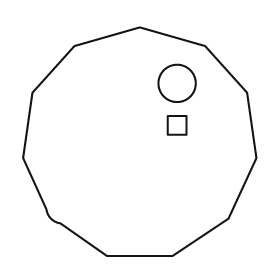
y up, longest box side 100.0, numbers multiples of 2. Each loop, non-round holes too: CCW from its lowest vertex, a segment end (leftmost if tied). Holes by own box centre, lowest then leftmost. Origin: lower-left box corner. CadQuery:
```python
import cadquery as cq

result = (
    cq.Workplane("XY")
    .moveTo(36.0, 0.0)
    .lineTo(64.0, 0.0)
    .lineTo(88.0, 16.0)
    .lineTo(100.0, 42.0)
    .lineTo(96.0, 70.0)
    .lineTo(78.0, 90.0)
    .lineTo(50.0, 98.0)
    .lineTo(22.0, 90.0)
    .lineTo(4.0, 70.0)
    .lineTo(0.0, 42.0)
    .lineTo(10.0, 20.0)
    .threePointArc((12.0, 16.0), (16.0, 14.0))
    .close()
    .moveTo(62.0, 52.0)
    .lineTo(70.0, 52.0)
    .lineTo(70.0, 60.0)
    .lineTo(62.0, 60.0)
    .close()
    .moveTo(66.0, 74.0)
    .circle(8.0)
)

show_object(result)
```